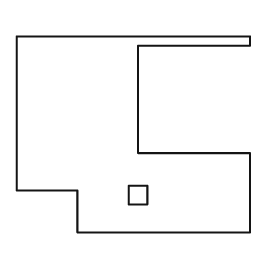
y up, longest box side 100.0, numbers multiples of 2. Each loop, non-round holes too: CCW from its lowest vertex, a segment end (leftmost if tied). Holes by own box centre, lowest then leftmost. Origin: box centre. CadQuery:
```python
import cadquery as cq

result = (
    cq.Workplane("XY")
    .moveTo(-24.0, -42.0)
    .lineTo(50.0, -42.0)
    .lineTo(50.0, -8.0)
    .lineTo(2.0, -8.0)
    .lineTo(2.0, 38.0)
    .lineTo(50.0, 38.0)
    .lineTo(50.0, 42.0)
    .lineTo(-50.0, 42.0)
    .lineTo(-50.0, -24.0)
    .lineTo(-24.0, -24.0)
    .close()
    .moveTo(-2.0, -30.0)
    .lineTo(6.0, -30.0)
    .lineTo(6.0, -22.0)
    .lineTo(-2.0, -22.0)
    .close()
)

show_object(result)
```